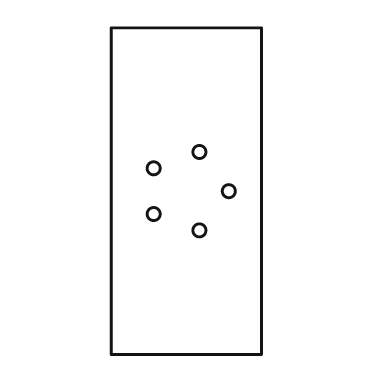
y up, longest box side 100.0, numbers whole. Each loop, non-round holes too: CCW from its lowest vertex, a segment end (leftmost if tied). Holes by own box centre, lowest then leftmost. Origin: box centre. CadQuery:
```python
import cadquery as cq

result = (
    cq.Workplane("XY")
    .moveTo(-23.0, -50.0)
    .lineTo(23.0, -50.0)
    .lineTo(23.0, 50.0)
    .lineTo(-23.0, 50.0)
    .close()
    .moveTo(4.0, -12.0)
    .circle(2.0)
    .moveTo(-10.0, -7.0)
    .circle(2.0)
    .moveTo(13.0, 0.0)
    .circle(2.0)
    .moveTo(-10.0, 7.0)
    .circle(2.0)
    .moveTo(4.0, 12.0)
    .circle(2.0)
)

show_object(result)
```